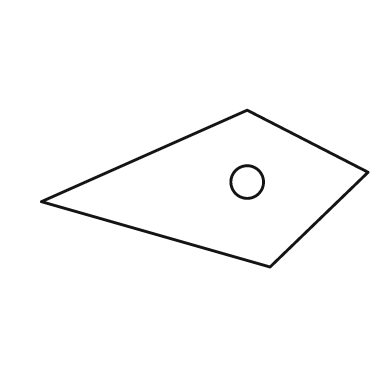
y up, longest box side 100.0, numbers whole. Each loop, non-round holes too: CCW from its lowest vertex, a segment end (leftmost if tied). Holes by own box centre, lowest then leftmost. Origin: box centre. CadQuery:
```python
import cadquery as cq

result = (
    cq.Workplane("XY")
    .moveTo(20.0, -24.0)
    .lineTo(50.0, 5.0)
    .lineTo(13.0, 24.0)
    .lineTo(-50.0, -4.0)
    .close()
    .moveTo(13.0, 2.0)
    .circle(5.0)
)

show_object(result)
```